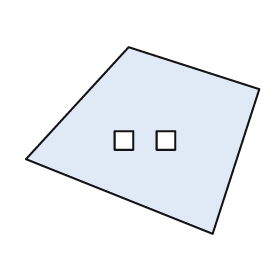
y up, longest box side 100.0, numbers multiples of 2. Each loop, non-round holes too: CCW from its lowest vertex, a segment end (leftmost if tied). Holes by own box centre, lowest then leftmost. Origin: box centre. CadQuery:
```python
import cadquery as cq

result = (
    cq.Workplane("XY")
    .moveTo(30.0, -40.0)
    .lineTo(50.0, 22.0)
    .lineTo(-6.0, 40.0)
    .lineTo(-50.0, -8.0)
    .close()
    .moveTo(-12.0, -4.0)
    .lineTo(-4.0, -4.0)
    .lineTo(-4.0, 4.0)
    .lineTo(-12.0, 4.0)
    .close()
    .moveTo(6.0, -4.0)
    .lineTo(14.0, -4.0)
    .lineTo(14.0, 4.0)
    .lineTo(6.0, 4.0)
    .close()
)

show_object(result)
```